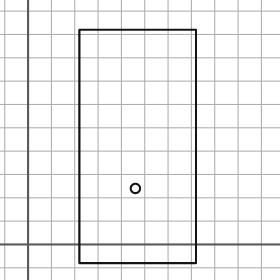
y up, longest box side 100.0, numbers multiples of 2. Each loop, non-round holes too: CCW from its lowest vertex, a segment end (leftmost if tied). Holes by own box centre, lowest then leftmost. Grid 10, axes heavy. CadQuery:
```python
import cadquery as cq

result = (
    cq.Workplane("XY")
    .moveTo(22.0, -8.0)
    .lineTo(72.0, -8.0)
    .lineTo(72.0, 92.0)
    .lineTo(22.0, 92.0)
    .close()
    .moveTo(46.0, 24.0)
    .circle(2.0)
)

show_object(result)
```